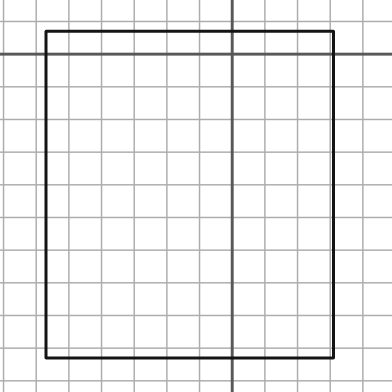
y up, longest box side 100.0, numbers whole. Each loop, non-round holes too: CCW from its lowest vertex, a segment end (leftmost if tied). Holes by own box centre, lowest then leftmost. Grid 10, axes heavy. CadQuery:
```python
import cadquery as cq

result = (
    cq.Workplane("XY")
    .moveTo(-57.0, -93.0)
    .lineTo(31.0, -93.0)
    .lineTo(31.0, 7.0)
    .lineTo(-57.0, 7.0)
    .close()
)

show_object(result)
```